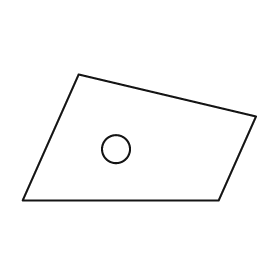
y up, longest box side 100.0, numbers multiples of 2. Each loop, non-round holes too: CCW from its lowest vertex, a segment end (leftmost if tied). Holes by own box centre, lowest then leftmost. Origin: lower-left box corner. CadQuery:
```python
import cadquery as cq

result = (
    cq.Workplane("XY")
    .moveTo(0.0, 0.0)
    .lineTo(84.0, 0.0)
    .lineTo(100.0, 36.0)
    .lineTo(24.0, 54.0)
    .close()
    .moveTo(40.0, 22.0)
    .circle(6.0)
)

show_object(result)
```